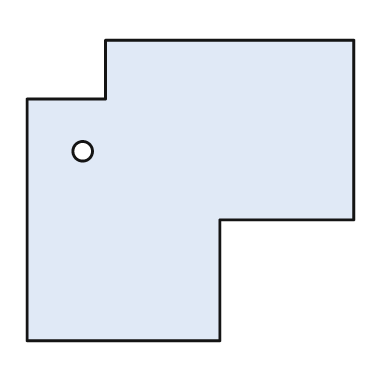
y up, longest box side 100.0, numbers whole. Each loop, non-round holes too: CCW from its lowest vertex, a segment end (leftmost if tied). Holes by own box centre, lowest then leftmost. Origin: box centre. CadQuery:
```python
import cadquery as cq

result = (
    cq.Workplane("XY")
    .moveTo(-50.0, -46.0)
    .lineTo(9.0, -46.0)
    .lineTo(9.0, -9.0)
    .lineTo(50.0, -9.0)
    .lineTo(50.0, 46.0)
    .lineTo(-26.0, 46.0)
    .lineTo(-26.0, 28.0)
    .lineTo(-50.0, 28.0)
    .close()
    .moveTo(-33.0, 12.0)
    .circle(3.0)
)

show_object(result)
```